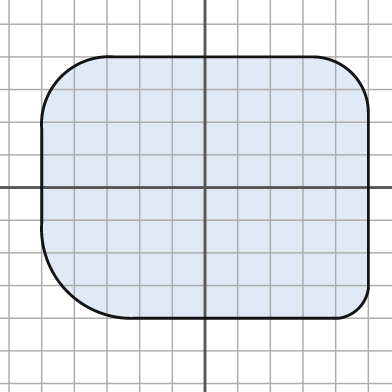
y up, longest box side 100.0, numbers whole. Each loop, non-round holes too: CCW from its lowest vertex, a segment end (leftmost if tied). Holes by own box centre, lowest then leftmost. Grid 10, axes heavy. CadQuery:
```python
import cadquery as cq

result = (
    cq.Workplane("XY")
    .moveTo(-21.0, -40.0)
    .lineTo(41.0, -40.0)
    .threePointArc((47.0, -37.0), (50.0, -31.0))
    .lineTo(50.0, 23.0)
    .threePointArc((45.0, 35.0), (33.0, 40.0))
    .lineTo(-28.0, 40.0)
    .threePointArc((-44.0, 34.0), (-50.0, 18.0))
    .lineTo(-50.0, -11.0)
    .threePointArc((-42.0, -32.0), (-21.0, -40.0))
    .close()
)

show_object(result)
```